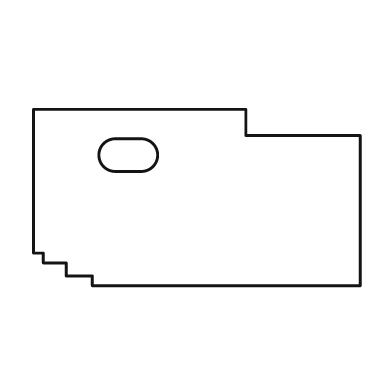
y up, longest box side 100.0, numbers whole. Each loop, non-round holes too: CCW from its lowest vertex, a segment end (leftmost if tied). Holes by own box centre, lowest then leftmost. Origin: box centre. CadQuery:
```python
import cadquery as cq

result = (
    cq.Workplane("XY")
    .moveTo(-32.0, -27.0)
    .lineTo(50.0, -27.0)
    .lineTo(50.0, 19.0)
    .lineTo(15.0, 19.0)
    .lineTo(15.0, 27.0)
    .lineTo(-50.0, 27.0)
    .lineTo(-50.0, -17.0)
    .lineTo(-47.0, -17.0)
    .lineTo(-47.0, -20.0)
    .lineTo(-40.0, -20.0)
    .lineTo(-40.0, -24.0)
    .lineTo(-32.0, -24.0)
    .close()
    .moveTo(-25.0, 8.0)
    .lineTo(-17.0, 8.0)
    .threePointArc((-12.0, 13.0), (-17.0, 18.0))
    .lineTo(-25.0, 18.0)
    .threePointArc((-30.0, 13.0), (-25.0, 8.0))
    .close()
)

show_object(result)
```